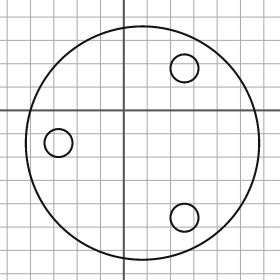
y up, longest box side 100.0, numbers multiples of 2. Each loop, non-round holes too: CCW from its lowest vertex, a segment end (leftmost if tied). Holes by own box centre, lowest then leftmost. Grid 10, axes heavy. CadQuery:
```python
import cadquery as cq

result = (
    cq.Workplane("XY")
    .moveTo(8.0, -14.0)
    .circle(50.0)
    .moveTo(26.0, -46.0)
    .circle(6.0)
    .moveTo(-28.0, -14.0)
    .circle(6.0)
    .moveTo(26.0, 18.0)
    .circle(6.0)
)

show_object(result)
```